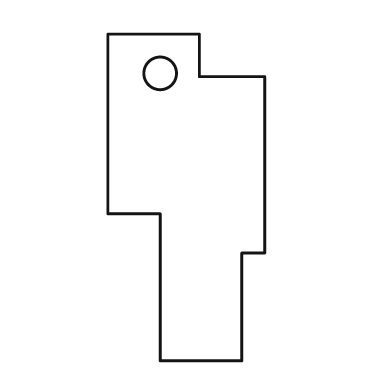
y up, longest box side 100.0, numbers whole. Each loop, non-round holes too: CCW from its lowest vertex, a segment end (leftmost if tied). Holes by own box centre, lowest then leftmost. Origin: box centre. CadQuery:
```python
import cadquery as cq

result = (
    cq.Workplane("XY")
    .moveTo(-8.0, -50.0)
    .lineTo(17.0, -50.0)
    .lineTo(17.0, -17.0)
    .lineTo(24.0, -17.0)
    .lineTo(24.0, 37.0)
    .lineTo(4.0, 37.0)
    .lineTo(4.0, 50.0)
    .lineTo(-24.0, 50.0)
    .lineTo(-24.0, -5.0)
    .lineTo(-8.0, -5.0)
    .close()
    .moveTo(-8.0, 38.0)
    .circle(5.0)
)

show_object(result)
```